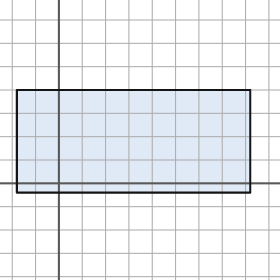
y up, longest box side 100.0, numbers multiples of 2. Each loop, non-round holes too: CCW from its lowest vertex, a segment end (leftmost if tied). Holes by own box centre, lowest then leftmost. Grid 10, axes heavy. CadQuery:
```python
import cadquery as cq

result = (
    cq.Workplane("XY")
    .moveTo(-18.0, -4.0)
    .lineTo(82.0, -4.0)
    .lineTo(82.0, 40.0)
    .lineTo(-18.0, 40.0)
    .close()
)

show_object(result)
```